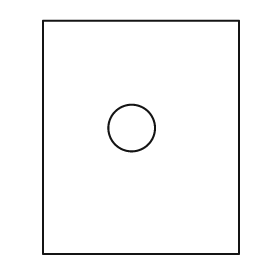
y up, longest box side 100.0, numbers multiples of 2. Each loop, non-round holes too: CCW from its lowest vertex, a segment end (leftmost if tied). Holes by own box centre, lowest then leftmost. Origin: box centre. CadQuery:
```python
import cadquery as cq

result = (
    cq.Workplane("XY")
    .moveTo(-42.0, -50.0)
    .lineTo(42.0, -50.0)
    .lineTo(42.0, 50.0)
    .lineTo(-42.0, 50.0)
    .close()
    .moveTo(-4.0, 4.0)
    .circle(10.0)
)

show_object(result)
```